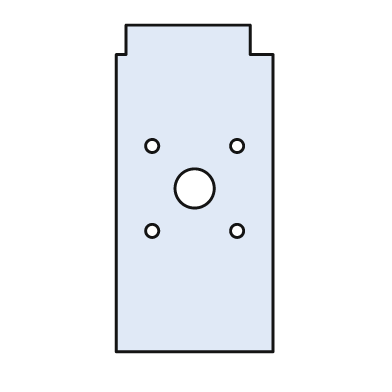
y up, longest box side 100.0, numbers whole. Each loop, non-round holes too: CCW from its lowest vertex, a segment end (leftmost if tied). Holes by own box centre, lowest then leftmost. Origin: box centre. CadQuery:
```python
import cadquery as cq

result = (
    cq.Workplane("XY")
    .moveTo(-24.0, -50.0)
    .lineTo(24.0, -50.0)
    .lineTo(24.0, 41.0)
    .lineTo(17.0, 41.0)
    .lineTo(17.0, 50.0)
    .lineTo(-21.0, 50.0)
    .lineTo(-21.0, 41.0)
    .lineTo(-24.0, 41.0)
    .close()
    .moveTo(-13.0, -13.0)
    .circle(2.0)
    .moveTo(13.0, -13.0)
    .circle(2.0)
    .moveTo(0.0, 0.0)
    .circle(6.0)
    .moveTo(-13.0, 13.0)
    .circle(2.0)
    .moveTo(13.0, 13.0)
    .circle(2.0)
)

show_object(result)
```